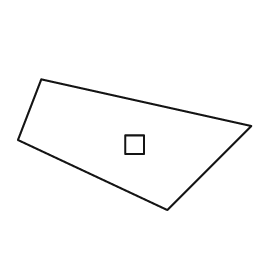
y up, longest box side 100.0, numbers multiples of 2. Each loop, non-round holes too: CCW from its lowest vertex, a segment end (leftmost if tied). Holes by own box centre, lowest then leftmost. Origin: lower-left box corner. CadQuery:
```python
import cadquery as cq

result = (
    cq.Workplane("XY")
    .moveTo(64.0, 0.0)
    .lineTo(100.0, 36.0)
    .lineTo(10.0, 56.0)
    .lineTo(0.0, 30.0)
    .close()
    .moveTo(46.0, 24.0)
    .lineTo(54.0, 24.0)
    .lineTo(54.0, 32.0)
    .lineTo(46.0, 32.0)
    .close()
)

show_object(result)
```